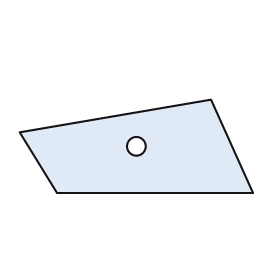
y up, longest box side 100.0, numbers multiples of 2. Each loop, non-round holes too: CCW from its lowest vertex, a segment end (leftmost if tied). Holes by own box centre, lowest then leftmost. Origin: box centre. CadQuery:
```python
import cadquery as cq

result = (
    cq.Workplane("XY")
    .moveTo(-34.0, -20.0)
    .lineTo(50.0, -20.0)
    .lineTo(32.0, 20.0)
    .lineTo(-50.0, 6.0)
    .close()
    .moveTo(0.0, 0.0)
    .circle(4.0)
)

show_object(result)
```